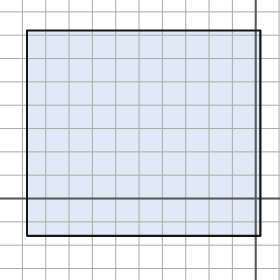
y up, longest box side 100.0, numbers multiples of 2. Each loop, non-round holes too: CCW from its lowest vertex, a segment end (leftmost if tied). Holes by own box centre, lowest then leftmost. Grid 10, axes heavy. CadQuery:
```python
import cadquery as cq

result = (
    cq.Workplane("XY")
    .moveTo(-98.0, -16.0)
    .lineTo(2.0, -16.0)
    .lineTo(2.0, 72.0)
    .lineTo(-98.0, 72.0)
    .close()
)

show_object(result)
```